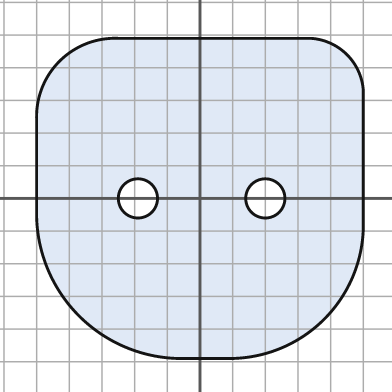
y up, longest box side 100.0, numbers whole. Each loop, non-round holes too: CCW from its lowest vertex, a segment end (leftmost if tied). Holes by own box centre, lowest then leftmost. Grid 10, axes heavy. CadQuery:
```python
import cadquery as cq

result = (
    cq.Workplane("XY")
    .moveTo(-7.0, -49.0)
    .lineTo(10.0, -49.0)
    .threePointArc((38.0, -37.0), (50.0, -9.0))
    .lineTo(50.0, 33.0)
    .threePointArc((45.0, 44.0), (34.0, 49.0))
    .lineTo(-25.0, 49.0)
    .threePointArc((-43.0, 42.0), (-50.0, 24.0))
    .lineTo(-50.0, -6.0)
    .threePointArc((-37.0, -36.0), (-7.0, -49.0))
    .close()
    .moveTo(-19.0, 0.0)
    .circle(6.0)
    .moveTo(20.0, 0.0)
    .circle(6.0)
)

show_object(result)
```